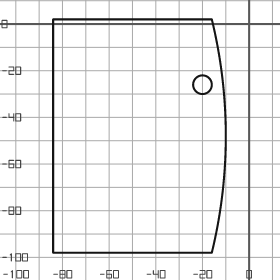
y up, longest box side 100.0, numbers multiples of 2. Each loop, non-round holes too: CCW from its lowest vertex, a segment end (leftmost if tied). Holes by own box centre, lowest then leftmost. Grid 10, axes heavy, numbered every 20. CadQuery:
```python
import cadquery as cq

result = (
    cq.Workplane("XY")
    .moveTo(-84.0, -98.0)
    .lineTo(-16.0, -98.0)
    .threePointArc((-10.0, -48.0), (-16.0, 2.0))
    .lineTo(-84.0, 2.0)
    .close()
    .moveTo(-20.0, -26.0)
    .circle(4.0)
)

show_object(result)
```